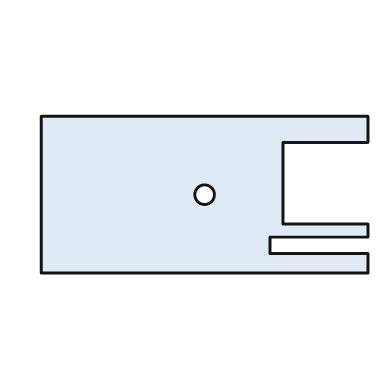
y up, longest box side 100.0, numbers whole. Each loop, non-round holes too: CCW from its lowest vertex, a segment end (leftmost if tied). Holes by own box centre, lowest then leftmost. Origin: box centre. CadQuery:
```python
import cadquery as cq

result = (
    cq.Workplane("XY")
    .moveTo(-50.0, -24.0)
    .lineTo(50.0, -24.0)
    .lineTo(50.0, -18.0)
    .lineTo(20.0, -18.0)
    .lineTo(20.0, -13.0)
    .lineTo(50.0, -13.0)
    .lineTo(50.0, -9.0)
    .lineTo(24.0, -9.0)
    .lineTo(24.0, 16.0)
    .lineTo(50.0, 16.0)
    .lineTo(50.0, 24.0)
    .lineTo(-50.0, 24.0)
    .close()
    .moveTo(0.0, 0.0)
    .circle(3.0)
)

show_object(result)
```